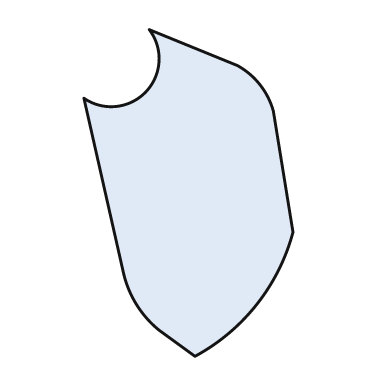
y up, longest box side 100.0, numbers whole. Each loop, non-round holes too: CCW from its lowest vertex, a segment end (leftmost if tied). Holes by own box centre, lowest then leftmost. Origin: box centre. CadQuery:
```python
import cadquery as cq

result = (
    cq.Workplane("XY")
    .moveTo(2.0, -50.0)
    .threePointArc((21.0, -34.0), (32.0, -12.0))
    .lineTo(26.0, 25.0)
    .threePointArc((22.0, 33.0), (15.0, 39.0))
    .lineTo(-12.0, 50.0)
    .threePointArc((-13.0, 31.0), (-32.0, 29.0))
    .lineTo(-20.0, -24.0)
    .threePointArc((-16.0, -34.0), (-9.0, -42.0))
    .close()
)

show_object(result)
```